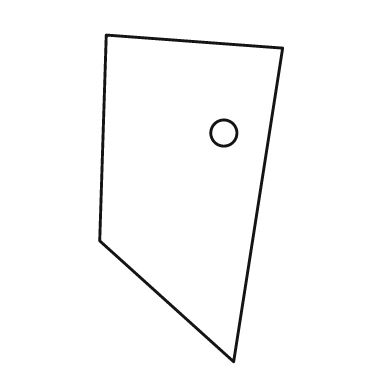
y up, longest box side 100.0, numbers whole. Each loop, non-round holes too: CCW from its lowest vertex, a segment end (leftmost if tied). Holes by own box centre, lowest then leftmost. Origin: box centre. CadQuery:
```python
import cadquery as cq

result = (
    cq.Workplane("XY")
    .moveTo(13.0, -50.0)
    .lineTo(28.0, 46.0)
    .lineTo(-26.0, 50.0)
    .lineTo(-28.0, -13.0)
    .close()
    .moveTo(10.0, 20.0)
    .circle(4.0)
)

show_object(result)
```